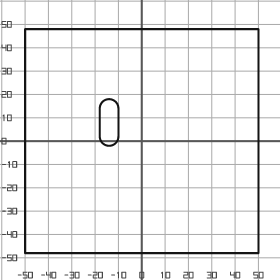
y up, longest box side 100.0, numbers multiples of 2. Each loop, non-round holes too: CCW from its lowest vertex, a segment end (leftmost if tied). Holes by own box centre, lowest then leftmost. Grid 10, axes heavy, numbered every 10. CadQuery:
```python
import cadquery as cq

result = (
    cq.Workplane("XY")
    .moveTo(-50.0, -48.0)
    .lineTo(50.0, -48.0)
    .lineTo(50.0, 48.0)
    .lineTo(-50.0, 48.0)
    .close()
    .moveTo(-18.0, 2.0)
    .threePointArc((-14.0, -2.0), (-10.0, 2.0))
    .lineTo(-10.0, 14.0)
    .threePointArc((-14.0, 18.0), (-18.0, 14.0))
    .close()
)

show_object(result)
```